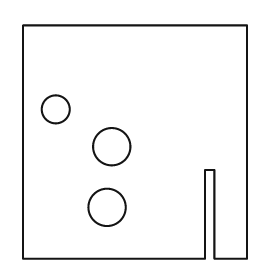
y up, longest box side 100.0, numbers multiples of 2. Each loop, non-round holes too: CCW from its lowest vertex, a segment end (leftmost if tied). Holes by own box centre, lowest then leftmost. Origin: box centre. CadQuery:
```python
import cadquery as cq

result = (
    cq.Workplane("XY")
    .moveTo(-48.0, -50.0)
    .lineTo(30.0, -50.0)
    .lineTo(30.0, -12.0)
    .lineTo(34.0, -12.0)
    .lineTo(34.0, -50.0)
    .lineTo(48.0, -50.0)
    .lineTo(48.0, 50.0)
    .lineTo(-48.0, 50.0)
    .close()
    .moveTo(-12.0, -28.0)
    .circle(8.0)
    .moveTo(-10.0, -2.0)
    .circle(8.0)
    .moveTo(-34.0, 14.0)
    .circle(6.0)
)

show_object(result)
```